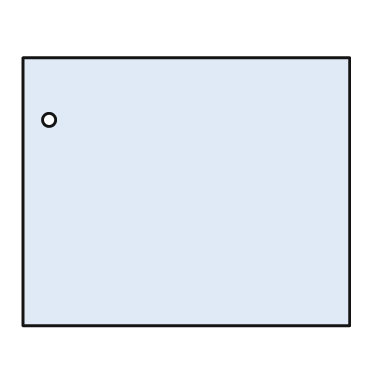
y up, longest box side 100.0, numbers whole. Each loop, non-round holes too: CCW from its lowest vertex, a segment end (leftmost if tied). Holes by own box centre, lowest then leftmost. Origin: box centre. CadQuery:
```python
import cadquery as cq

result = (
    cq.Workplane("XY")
    .moveTo(-50.0, -41.0)
    .lineTo(50.0, -41.0)
    .lineTo(50.0, 41.0)
    .lineTo(-50.0, 41.0)
    .close()
    .moveTo(-42.0, 22.0)
    .circle(2.0)
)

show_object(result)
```